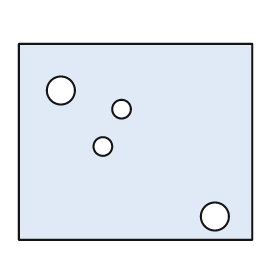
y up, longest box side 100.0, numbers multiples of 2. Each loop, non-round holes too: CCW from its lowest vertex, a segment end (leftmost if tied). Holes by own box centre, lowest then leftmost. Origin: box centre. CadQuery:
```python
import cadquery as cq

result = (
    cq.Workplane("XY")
    .moveTo(-50.0, -42.0)
    .lineTo(50.0, -42.0)
    .lineTo(50.0, 42.0)
    .lineTo(-50.0, 42.0)
    .close()
    .moveTo(34.0, -32.0)
    .circle(6.0)
    .moveTo(-14.0, -2.0)
    .circle(4.0)
    .moveTo(-6.0, 14.0)
    .circle(4.0)
    .moveTo(-32.0, 22.0)
    .circle(6.0)
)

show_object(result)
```